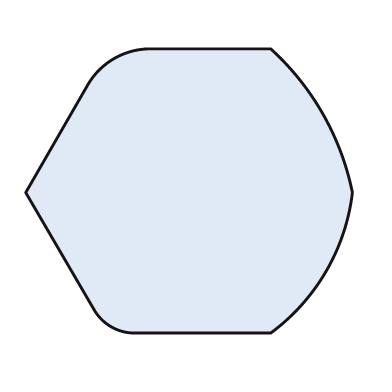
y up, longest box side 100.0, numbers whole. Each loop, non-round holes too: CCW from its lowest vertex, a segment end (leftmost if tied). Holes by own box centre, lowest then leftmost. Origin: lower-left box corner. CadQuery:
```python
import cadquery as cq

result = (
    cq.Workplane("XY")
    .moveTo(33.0, 0.0)
    .lineTo(75.0, 0.0)
    .threePointArc((92.0, 19.0), (100.0, 43.0))
    .threePointArc((91.0, 67.0), (75.0, 87.0))
    .lineTo(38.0, 87.0)
    .threePointArc((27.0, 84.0), (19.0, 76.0))
    .lineTo(0.0, 43.0)
    .lineTo(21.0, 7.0)
    .threePointArc((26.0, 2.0), (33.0, 0.0))
    .close()
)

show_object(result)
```